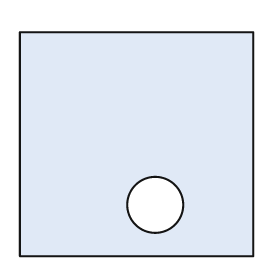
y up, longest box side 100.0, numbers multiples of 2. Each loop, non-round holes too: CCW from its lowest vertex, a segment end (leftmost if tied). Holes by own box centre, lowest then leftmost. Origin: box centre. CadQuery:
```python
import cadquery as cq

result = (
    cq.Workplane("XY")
    .moveTo(-50.0, -48.0)
    .lineTo(50.0, -48.0)
    .lineTo(50.0, 48.0)
    .lineTo(-50.0, 48.0)
    .close()
    .moveTo(8.0, -26.0)
    .circle(12.0)
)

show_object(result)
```